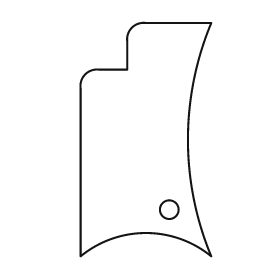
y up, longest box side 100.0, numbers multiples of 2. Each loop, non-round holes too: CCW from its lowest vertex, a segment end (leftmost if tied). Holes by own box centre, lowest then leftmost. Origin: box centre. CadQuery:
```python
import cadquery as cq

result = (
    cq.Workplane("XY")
    .moveTo(-28.0, -50.0)
    .threePointArc((0.0, -40.0), (28.0, -50.0))
    .threePointArc((18.0, 0.0), (28.0, 50.0))
    .lineTo(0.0, 50.0)
    .threePointArc((-6.0, 48.0), (-8.0, 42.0))
    .lineTo(-8.0, 30.0)
    .lineTo(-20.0, 30.0)
    .threePointArc((-26.0, 28.0), (-28.0, 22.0))
    .close()
    .moveTo(10.0, -30.0)
    .circle(4.0)
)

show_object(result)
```